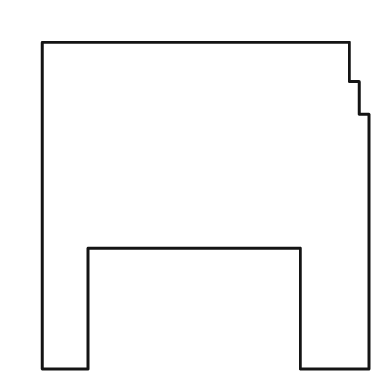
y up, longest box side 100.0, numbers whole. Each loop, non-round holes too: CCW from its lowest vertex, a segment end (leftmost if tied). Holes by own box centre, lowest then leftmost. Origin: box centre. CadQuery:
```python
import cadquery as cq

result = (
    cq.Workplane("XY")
    .moveTo(-50.0, -50.0)
    .lineTo(-36.0, -50.0)
    .lineTo(-36.0, -13.0)
    .lineTo(29.0, -13.0)
    .lineTo(29.0, -50.0)
    .lineTo(50.0, -50.0)
    .lineTo(50.0, 28.0)
    .lineTo(47.0, 28.0)
    .lineTo(47.0, 38.0)
    .lineTo(44.0, 38.0)
    .lineTo(44.0, 50.0)
    .lineTo(-50.0, 50.0)
    .close()
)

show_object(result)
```